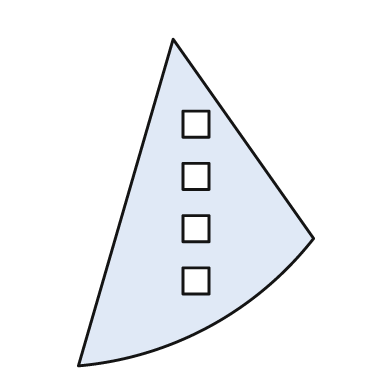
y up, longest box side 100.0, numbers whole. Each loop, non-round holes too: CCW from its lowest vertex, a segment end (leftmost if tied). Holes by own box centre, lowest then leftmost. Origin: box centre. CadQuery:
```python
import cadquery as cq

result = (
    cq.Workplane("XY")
    .moveTo(-36.0, -50.0)
    .threePointArc((4.0, -38.0), (36.0, -11.0))
    .lineTo(-7.0, 50.0)
    .close()
    .moveTo(-4.0, -28.0)
    .lineTo(4.0, -28.0)
    .lineTo(4.0, -20.0)
    .lineTo(-4.0, -20.0)
    .close()
    .moveTo(-4.0, -12.0)
    .lineTo(4.0, -12.0)
    .lineTo(4.0, -4.0)
    .lineTo(-4.0, -4.0)
    .close()
    .moveTo(-4.0, 4.0)
    .lineTo(4.0, 4.0)
    .lineTo(4.0, 12.0)
    .lineTo(-4.0, 12.0)
    .close()
    .moveTo(-4.0, 20.0)
    .lineTo(4.0, 20.0)
    .lineTo(4.0, 28.0)
    .lineTo(-4.0, 28.0)
    .close()
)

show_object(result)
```